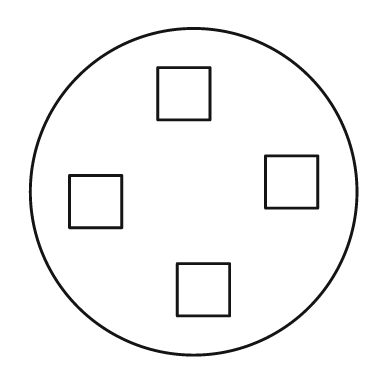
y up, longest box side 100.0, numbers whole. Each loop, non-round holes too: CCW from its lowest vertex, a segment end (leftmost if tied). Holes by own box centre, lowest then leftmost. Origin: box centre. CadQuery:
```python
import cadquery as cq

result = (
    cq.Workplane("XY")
    .moveTo(0.0, 0.0)
    .circle(50.0)
    .moveTo(-5.0, -38.0)
    .lineTo(11.0, -38.0)
    .lineTo(11.0, -22.0)
    .lineTo(-5.0, -22.0)
    .close()
    .moveTo(-38.0, -11.0)
    .lineTo(-22.0, -11.0)
    .lineTo(-22.0, 5.0)
    .lineTo(-38.0, 5.0)
    .close()
    .moveTo(22.0, -5.0)
    .lineTo(38.0, -5.0)
    .lineTo(38.0, 11.0)
    .lineTo(22.0, 11.0)
    .close()
    .moveTo(-11.0, 22.0)
    .lineTo(5.0, 22.0)
    .lineTo(5.0, 38.0)
    .lineTo(-11.0, 38.0)
    .close()
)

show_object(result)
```